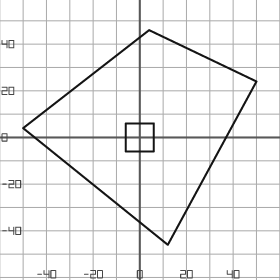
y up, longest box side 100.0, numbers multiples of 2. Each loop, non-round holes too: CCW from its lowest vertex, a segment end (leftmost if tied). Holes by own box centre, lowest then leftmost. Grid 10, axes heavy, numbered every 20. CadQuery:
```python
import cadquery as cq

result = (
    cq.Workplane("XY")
    .moveTo(12.0, -46.0)
    .lineTo(50.0, 24.0)
    .lineTo(4.0, 46.0)
    .lineTo(-50.0, 4.0)
    .close()
    .moveTo(-6.0, -6.0)
    .lineTo(6.0, -6.0)
    .lineTo(6.0, 6.0)
    .lineTo(-6.0, 6.0)
    .close()
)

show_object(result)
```